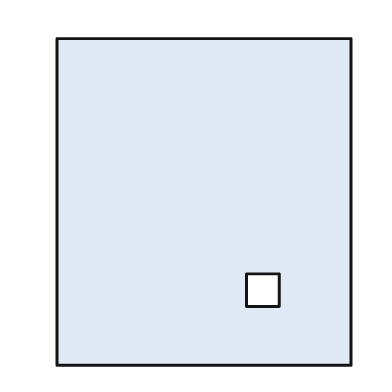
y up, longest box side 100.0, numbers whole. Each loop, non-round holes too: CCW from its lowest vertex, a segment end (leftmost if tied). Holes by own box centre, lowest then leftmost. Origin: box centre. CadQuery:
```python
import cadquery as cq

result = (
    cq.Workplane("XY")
    .moveTo(-45.0, -50.0)
    .lineTo(45.0, -50.0)
    .lineTo(45.0, 50.0)
    .lineTo(-45.0, 50.0)
    .close()
    .moveTo(13.0, -32.0)
    .lineTo(23.0, -32.0)
    .lineTo(23.0, -22.0)
    .lineTo(13.0, -22.0)
    .close()
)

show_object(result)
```